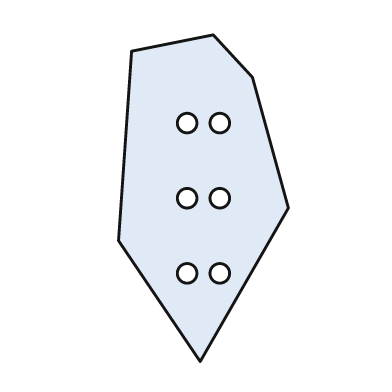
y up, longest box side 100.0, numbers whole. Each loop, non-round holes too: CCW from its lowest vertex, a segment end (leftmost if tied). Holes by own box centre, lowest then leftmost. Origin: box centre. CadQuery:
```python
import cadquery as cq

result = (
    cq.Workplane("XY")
    .moveTo(-1.0, -50.0)
    .lineTo(26.0, -3.0)
    .lineTo(15.0, 37.0)
    .lineTo(3.0, 50.0)
    .lineTo(-22.0, 45.0)
    .lineTo(-26.0, -13.0)
    .close()
    .moveTo(-5.0, -23.0)
    .circle(3.0)
    .moveTo(5.0, -23.0)
    .circle(3.0)
    .moveTo(-5.0, 0.0)
    .circle(3.0)
    .moveTo(5.0, 0.0)
    .circle(3.0)
    .moveTo(-5.0, 23.0)
    .circle(3.0)
    .moveTo(5.0, 23.0)
    .circle(3.0)
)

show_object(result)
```